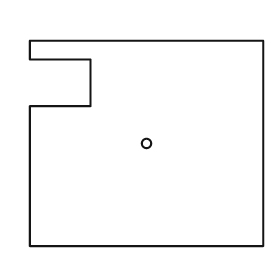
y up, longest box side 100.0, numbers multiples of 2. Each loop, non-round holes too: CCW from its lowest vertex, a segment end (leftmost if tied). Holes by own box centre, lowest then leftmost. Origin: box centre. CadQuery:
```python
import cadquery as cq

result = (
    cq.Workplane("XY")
    .moveTo(-50.0, -44.0)
    .lineTo(50.0, -44.0)
    .lineTo(50.0, 44.0)
    .lineTo(-50.0, 44.0)
    .lineTo(-50.0, 36.0)
    .lineTo(-24.0, 36.0)
    .lineTo(-24.0, 16.0)
    .lineTo(-50.0, 16.0)
    .close()
    .moveTo(0.0, 0.0)
    .circle(2.0)
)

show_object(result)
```